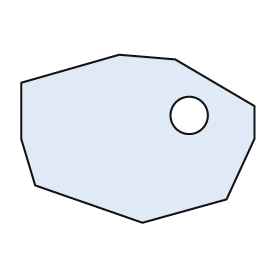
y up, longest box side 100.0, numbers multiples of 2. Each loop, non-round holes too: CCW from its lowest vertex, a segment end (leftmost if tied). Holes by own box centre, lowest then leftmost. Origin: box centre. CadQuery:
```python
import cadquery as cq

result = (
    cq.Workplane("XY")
    .moveTo(2.0, -36.0)
    .lineTo(38.0, -26.0)
    .lineTo(50.0, 0.0)
    .lineTo(50.0, 14.0)
    .lineTo(16.0, 34.0)
    .lineTo(-8.0, 36.0)
    .lineTo(-50.0, 24.0)
    .lineTo(-50.0, 0.0)
    .lineTo(-44.0, -20.0)
    .close()
    .moveTo(22.0, 10.0)
    .circle(8.0)
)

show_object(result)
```